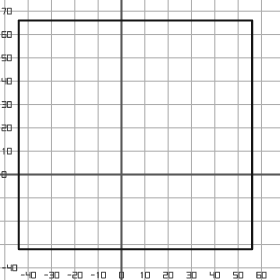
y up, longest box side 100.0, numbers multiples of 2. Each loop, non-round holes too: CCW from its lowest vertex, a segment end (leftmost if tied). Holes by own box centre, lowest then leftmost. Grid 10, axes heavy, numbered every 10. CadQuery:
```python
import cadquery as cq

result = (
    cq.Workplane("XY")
    .moveTo(-44.0, -32.0)
    .lineTo(56.0, -32.0)
    .lineTo(56.0, 66.0)
    .lineTo(-44.0, 66.0)
    .close()
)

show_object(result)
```